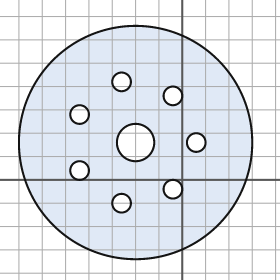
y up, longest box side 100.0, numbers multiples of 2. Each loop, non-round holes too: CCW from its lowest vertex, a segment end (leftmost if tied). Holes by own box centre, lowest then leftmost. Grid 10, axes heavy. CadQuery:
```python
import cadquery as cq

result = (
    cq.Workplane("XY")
    .moveTo(-20.0, 16.0)
    .circle(50.0)
    .moveTo(-26.0, -10.0)
    .circle(4.0)
    .moveTo(-4.0, -4.0)
    .circle(4.0)
    .moveTo(-44.0, 4.0)
    .circle(4.0)
    .moveTo(-20.0, 16.0)
    .circle(8.0)
    .moveTo(6.0, 16.0)
    .circle(4.0)
    .moveTo(-44.0, 28.0)
    .circle(4.0)
    .moveTo(-4.0, 36.0)
    .circle(4.0)
    .moveTo(-26.0, 42.0)
    .circle(4.0)
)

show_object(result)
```